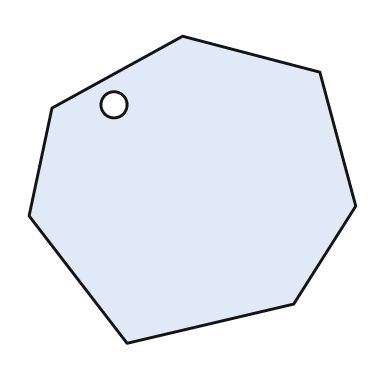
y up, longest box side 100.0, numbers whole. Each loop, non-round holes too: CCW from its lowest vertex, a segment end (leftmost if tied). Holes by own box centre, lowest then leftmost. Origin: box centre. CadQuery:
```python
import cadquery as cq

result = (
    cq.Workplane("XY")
    .moveTo(-20.0, -47.0)
    .lineTo(31.0, -35.0)
    .lineTo(50.0, -5.0)
    .lineTo(39.0, 36.0)
    .lineTo(-3.0, 47.0)
    .lineTo(-43.0, 25.0)
    .lineTo(-50.0, -8.0)
    .close()
    .moveTo(-24.0, 26.0)
    .circle(4.0)
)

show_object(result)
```